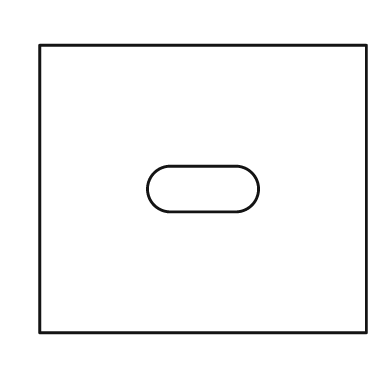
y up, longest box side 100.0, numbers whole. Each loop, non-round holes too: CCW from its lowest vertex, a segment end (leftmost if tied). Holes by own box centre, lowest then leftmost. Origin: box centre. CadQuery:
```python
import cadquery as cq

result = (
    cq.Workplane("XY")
    .moveTo(-50.0, -44.0)
    .lineTo(50.0, -44.0)
    .lineTo(50.0, 44.0)
    .lineTo(-50.0, 44.0)
    .close()
    .moveTo(-10.0, -7.0)
    .lineTo(10.0, -7.0)
    .threePointArc((17.0, 0.0), (10.0, 7.0))
    .lineTo(-10.0, 7.0)
    .threePointArc((-17.0, 0.0), (-10.0, -7.0))
    .close()
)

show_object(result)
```